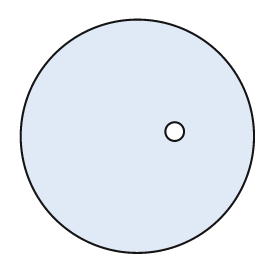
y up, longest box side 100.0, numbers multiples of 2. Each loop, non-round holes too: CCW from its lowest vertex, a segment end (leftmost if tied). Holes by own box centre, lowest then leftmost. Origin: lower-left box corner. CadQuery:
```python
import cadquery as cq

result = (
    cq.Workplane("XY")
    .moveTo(50.0, 50.0)
    .circle(50.0)
    .moveTo(66.0, 52.0)
    .circle(4.0)
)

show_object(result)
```